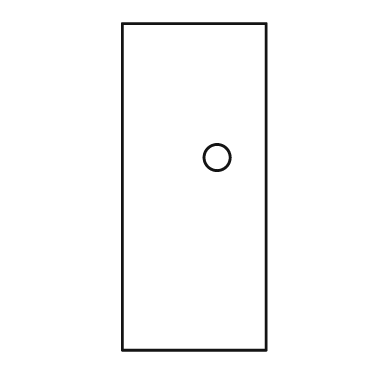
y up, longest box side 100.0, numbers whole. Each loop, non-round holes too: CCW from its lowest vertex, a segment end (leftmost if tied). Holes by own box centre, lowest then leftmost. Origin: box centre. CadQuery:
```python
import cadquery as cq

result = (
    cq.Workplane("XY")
    .moveTo(-22.0, -50.0)
    .lineTo(22.0, -50.0)
    .lineTo(22.0, 50.0)
    .lineTo(-22.0, 50.0)
    .close()
    .moveTo(7.0, 9.0)
    .circle(4.0)
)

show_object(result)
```